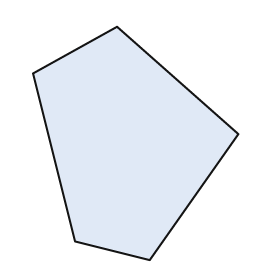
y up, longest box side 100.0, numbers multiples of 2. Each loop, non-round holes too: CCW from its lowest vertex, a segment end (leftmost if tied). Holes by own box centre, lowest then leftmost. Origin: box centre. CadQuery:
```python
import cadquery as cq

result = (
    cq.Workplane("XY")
    .moveTo(6.0, -50.0)
    .lineTo(44.0, 4.0)
    .lineTo(-8.0, 50.0)
    .lineTo(-44.0, 30.0)
    .lineTo(-26.0, -42.0)
    .close()
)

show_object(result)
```